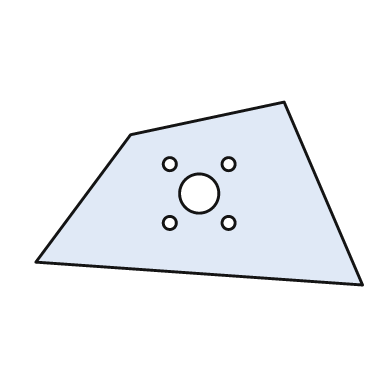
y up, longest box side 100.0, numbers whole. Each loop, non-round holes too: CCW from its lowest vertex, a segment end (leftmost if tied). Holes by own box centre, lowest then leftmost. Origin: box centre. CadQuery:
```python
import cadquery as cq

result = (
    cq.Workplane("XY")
    .moveTo(50.0, -28.0)
    .lineTo(26.0, 28.0)
    .lineTo(-21.0, 18.0)
    .lineTo(-50.0, -21.0)
    .close()
    .moveTo(-9.0, -9.0)
    .circle(2.0)
    .moveTo(9.0, -9.0)
    .circle(2.0)
    .moveTo(0.0, 0.0)
    .circle(6.0)
    .moveTo(-9.0, 9.0)
    .circle(2.0)
    .moveTo(9.0, 9.0)
    .circle(2.0)
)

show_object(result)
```